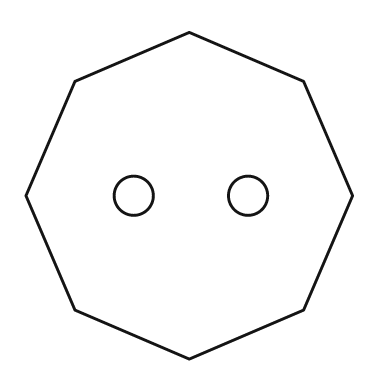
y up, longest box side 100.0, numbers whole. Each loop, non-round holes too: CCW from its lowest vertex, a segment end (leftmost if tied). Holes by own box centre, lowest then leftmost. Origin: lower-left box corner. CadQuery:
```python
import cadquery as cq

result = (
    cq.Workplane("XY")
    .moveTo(50.0, 0.0)
    .lineTo(85.0, 15.0)
    .lineTo(100.0, 50.0)
    .lineTo(85.0, 85.0)
    .lineTo(50.0, 100.0)
    .lineTo(15.0, 85.0)
    .lineTo(0.0, 50.0)
    .lineTo(15.0, 15.0)
    .close()
    .moveTo(33.0, 50.0)
    .circle(6.0)
    .moveTo(68.0, 50.0)
    .circle(6.0)
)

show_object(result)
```